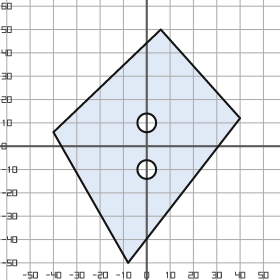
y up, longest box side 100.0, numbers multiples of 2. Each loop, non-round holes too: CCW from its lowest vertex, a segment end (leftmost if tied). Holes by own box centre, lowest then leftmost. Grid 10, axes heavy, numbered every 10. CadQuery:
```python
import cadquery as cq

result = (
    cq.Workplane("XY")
    .moveTo(-8.0, -50.0)
    .lineTo(40.0, 12.0)
    .lineTo(6.0, 50.0)
    .lineTo(-40.0, 6.0)
    .close()
    .moveTo(0.0, -10.0)
    .circle(4.0)
    .moveTo(0.0, 10.0)
    .circle(4.0)
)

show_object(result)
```